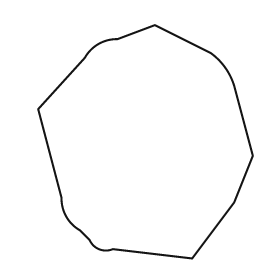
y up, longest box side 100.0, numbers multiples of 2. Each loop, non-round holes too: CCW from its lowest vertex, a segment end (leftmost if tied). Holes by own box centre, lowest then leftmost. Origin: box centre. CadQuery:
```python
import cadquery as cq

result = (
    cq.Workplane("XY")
    .moveTo(20.0, -50.0)
    .lineTo(38.0, -26.0)
    .lineTo(46.0, -6.0)
    .lineTo(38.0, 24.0)
    .threePointArc((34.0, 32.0), (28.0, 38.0))
    .lineTo(4.0, 50.0)
    .lineTo(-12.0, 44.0)
    .threePointArc((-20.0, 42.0), (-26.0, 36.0))
    .lineTo(-46.0, 14.0)
    .lineTo(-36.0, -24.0)
    .threePointArc((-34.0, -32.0), (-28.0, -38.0))
    .lineTo(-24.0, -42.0)
    .threePointArc((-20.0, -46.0), (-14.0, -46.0))
    .close()
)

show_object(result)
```